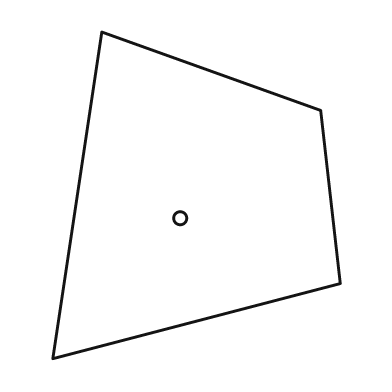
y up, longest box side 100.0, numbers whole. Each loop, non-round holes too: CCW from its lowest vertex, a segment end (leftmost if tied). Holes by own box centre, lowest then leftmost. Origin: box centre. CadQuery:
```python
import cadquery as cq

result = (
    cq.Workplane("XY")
    .moveTo(-44.0, -50.0)
    .lineTo(44.0, -27.0)
    .lineTo(38.0, 26.0)
    .lineTo(-29.0, 50.0)
    .close()
    .moveTo(-5.0, -7.0)
    .circle(2.0)
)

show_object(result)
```